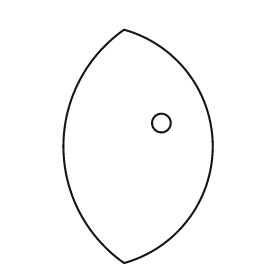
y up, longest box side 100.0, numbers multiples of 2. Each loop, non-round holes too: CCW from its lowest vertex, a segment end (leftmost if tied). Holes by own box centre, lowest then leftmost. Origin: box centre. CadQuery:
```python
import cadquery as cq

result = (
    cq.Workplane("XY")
    .moveTo(-6.0, -50.0)
    .threePointArc((32.0, 0.0), (-6.0, 50.0))
    .threePointArc((-32.0, 0.0), (-6.0, -50.0))
    .close()
    .moveTo(10.0, 10.0)
    .circle(4.0)
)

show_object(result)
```